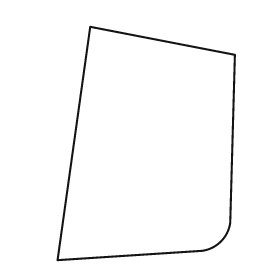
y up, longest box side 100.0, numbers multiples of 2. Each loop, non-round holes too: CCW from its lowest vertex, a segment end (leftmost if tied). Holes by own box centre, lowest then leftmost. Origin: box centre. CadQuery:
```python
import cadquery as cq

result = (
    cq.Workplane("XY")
    .moveTo(-38.0, -50.0)
    .lineTo(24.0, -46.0)
    .threePointArc((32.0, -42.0), (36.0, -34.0))
    .lineTo(38.0, 38.0)
    .lineTo(-24.0, 50.0)
    .close()
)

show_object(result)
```